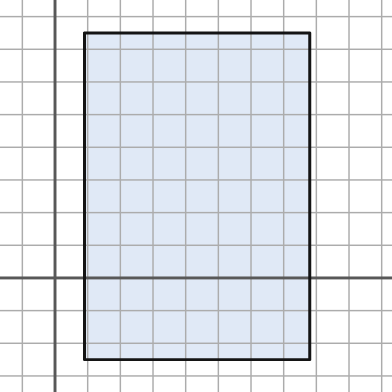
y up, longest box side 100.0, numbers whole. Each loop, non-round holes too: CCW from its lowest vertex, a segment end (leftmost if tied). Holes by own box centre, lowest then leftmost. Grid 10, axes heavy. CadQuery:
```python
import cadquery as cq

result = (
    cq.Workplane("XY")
    .moveTo(9.0, -25.0)
    .lineTo(78.0, -25.0)
    .lineTo(78.0, 75.0)
    .lineTo(9.0, 75.0)
    .close()
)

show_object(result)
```